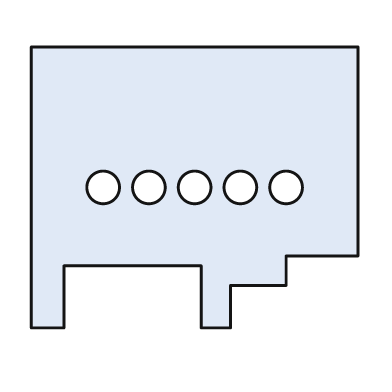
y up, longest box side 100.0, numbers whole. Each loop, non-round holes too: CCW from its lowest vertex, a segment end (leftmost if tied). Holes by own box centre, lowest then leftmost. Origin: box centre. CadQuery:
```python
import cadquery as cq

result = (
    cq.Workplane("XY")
    .moveTo(-50.0, -43.0)
    .lineTo(-40.0, -43.0)
    .lineTo(-40.0, -24.0)
    .lineTo(2.0, -24.0)
    .lineTo(2.0, -43.0)
    .lineTo(11.0, -43.0)
    .lineTo(11.0, -30.0)
    .lineTo(28.0, -30.0)
    .lineTo(28.0, -21.0)
    .lineTo(50.0, -21.0)
    .lineTo(50.0, 43.0)
    .lineTo(-50.0, 43.0)
    .close()
    .moveTo(-28.0, 0.0)
    .circle(5.0)
    .moveTo(-14.0, 0.0)
    .circle(5.0)
    .moveTo(0.0, 0.0)
    .circle(5.0)
    .moveTo(14.0, 0.0)
    .circle(5.0)
    .moveTo(28.0, 0.0)
    .circle(5.0)
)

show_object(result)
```